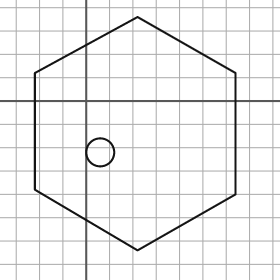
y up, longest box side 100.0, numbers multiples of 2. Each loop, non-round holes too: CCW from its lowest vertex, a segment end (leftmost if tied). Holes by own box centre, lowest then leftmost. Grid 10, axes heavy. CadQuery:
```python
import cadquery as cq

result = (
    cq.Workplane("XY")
    .moveTo(22.0, -64.0)
    .lineTo(64.0, -40.0)
    .lineTo(64.0, 12.0)
    .lineTo(22.0, 36.0)
    .lineTo(-22.0, 12.0)
    .lineTo(-22.0, -38.0)
    .close()
    .moveTo(6.0, -22.0)
    .circle(6.0)
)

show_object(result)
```